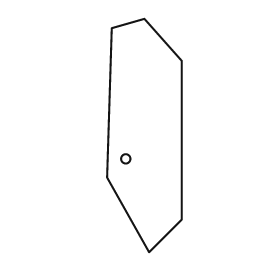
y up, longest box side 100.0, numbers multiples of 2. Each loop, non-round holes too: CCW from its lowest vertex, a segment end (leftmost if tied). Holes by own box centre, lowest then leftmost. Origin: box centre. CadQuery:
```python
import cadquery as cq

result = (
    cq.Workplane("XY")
    .moveTo(2.0, -50.0)
    .lineTo(16.0, -36.0)
    .lineTo(16.0, 32.0)
    .lineTo(0.0, 50.0)
    .lineTo(-14.0, 46.0)
    .lineTo(-16.0, -18.0)
    .close()
    .moveTo(-8.0, -10.0)
    .circle(2.0)
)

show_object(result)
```